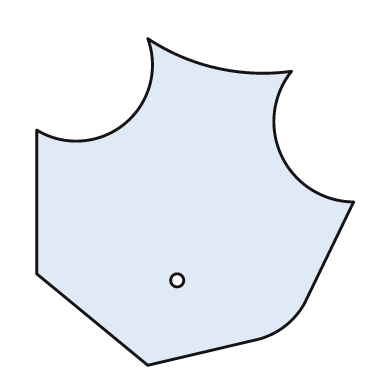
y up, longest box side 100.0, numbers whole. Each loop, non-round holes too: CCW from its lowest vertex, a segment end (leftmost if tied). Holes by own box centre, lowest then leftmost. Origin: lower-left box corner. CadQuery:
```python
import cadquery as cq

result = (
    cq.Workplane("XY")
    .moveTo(34.0, 0.0)
    .lineTo(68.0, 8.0)
    .threePointArc((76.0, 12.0), (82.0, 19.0))
    .lineTo(97.0, 50.0)
    .threePointArc((75.0, 64.0), (78.0, 90.0))
    .threePointArc((55.0, 91.0), (34.0, 100.0))
    .threePointArc((27.0, 74.0), (0.0, 72.0))
    .lineTo(0.0, 28.0)
    .close()
    .moveTo(43.0, 26.0)
    .circle(2.0)
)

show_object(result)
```